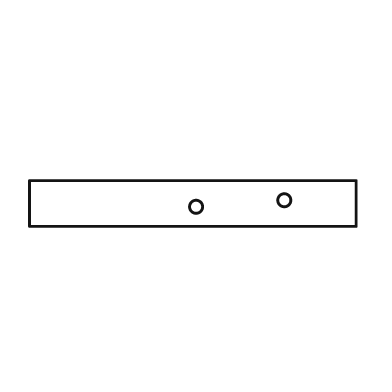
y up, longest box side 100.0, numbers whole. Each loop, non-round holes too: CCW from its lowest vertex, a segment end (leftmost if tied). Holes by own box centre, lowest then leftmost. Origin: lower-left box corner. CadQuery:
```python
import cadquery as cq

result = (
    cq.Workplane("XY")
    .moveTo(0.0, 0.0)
    .lineTo(100.0, 0.0)
    .lineTo(100.0, 14.0)
    .lineTo(0.0, 14.0)
    .close()
    .moveTo(51.0, 6.0)
    .circle(2.0)
    .moveTo(78.0, 8.0)
    .circle(2.0)
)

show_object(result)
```